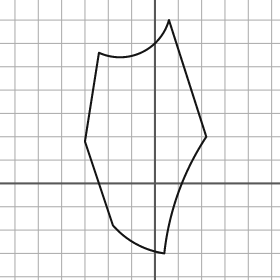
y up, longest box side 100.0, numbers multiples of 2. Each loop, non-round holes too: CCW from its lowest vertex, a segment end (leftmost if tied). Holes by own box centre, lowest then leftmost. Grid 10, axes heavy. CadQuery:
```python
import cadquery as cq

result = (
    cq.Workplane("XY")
    .moveTo(4.0, -30.0)
    .threePointArc((10.0, -4.0), (22.0, 20.0))
    .lineTo(6.0, 70.0)
    .threePointArc((-6.0, 56.0), (-24.0, 56.0))
    .lineTo(-30.0, 18.0)
    .lineTo(-18.0, -18.0)
    .threePointArc((-8.0, -26.0), (4.0, -30.0))
    .close()
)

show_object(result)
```